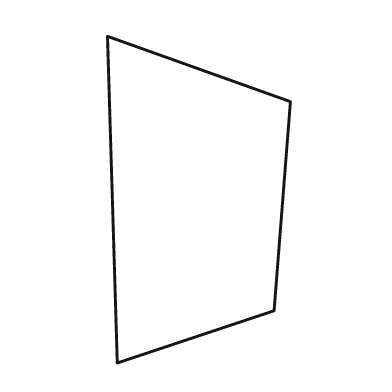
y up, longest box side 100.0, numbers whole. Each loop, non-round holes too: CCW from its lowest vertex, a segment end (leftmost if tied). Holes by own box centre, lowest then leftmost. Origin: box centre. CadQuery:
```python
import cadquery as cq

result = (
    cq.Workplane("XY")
    .moveTo(-25.0, -50.0)
    .lineTo(23.0, -34.0)
    .lineTo(28.0, 30.0)
    .lineTo(-28.0, 50.0)
    .close()
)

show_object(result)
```